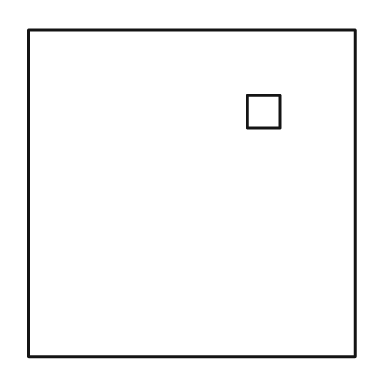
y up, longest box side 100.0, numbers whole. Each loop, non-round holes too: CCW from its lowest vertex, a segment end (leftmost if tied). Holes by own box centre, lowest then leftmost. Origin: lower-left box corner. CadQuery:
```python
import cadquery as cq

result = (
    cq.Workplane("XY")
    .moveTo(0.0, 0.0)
    .lineTo(100.0, 0.0)
    .lineTo(100.0, 100.0)
    .lineTo(0.0, 100.0)
    .close()
    .moveTo(67.0, 70.0)
    .lineTo(77.0, 70.0)
    .lineTo(77.0, 80.0)
    .lineTo(67.0, 80.0)
    .close()
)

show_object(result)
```